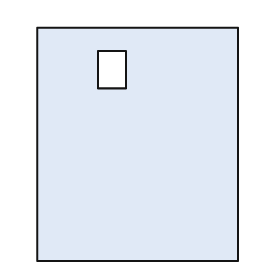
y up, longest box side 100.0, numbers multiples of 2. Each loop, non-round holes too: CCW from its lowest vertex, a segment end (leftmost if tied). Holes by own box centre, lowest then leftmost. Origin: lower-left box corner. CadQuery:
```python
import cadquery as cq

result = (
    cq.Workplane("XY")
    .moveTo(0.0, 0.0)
    .lineTo(86.0, 0.0)
    .lineTo(86.0, 100.0)
    .lineTo(0.0, 100.0)
    .close()
    .moveTo(26.0, 74.0)
    .lineTo(38.0, 74.0)
    .lineTo(38.0, 90.0)
    .lineTo(26.0, 90.0)
    .close()
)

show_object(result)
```